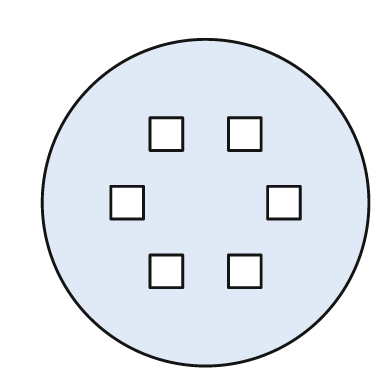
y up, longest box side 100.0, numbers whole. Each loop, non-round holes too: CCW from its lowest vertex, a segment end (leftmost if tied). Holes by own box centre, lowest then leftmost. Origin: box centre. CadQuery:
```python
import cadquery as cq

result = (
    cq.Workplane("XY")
    .moveTo(0.0, 0.0)
    .circle(50.0)
    .moveTo(-17.0, -26.0)
    .lineTo(-7.0, -26.0)
    .lineTo(-7.0, -16.0)
    .lineTo(-17.0, -16.0)
    .close()
    .moveTo(7.0, -26.0)
    .lineTo(17.0, -26.0)
    .lineTo(17.0, -16.0)
    .lineTo(7.0, -16.0)
    .close()
    .moveTo(-29.0, -5.0)
    .lineTo(-19.0, -5.0)
    .lineTo(-19.0, 5.0)
    .lineTo(-29.0, 5.0)
    .close()
    .moveTo(19.0, -5.0)
    .lineTo(29.0, -5.0)
    .lineTo(29.0, 5.0)
    .lineTo(19.0, 5.0)
    .close()
    .moveTo(-17.0, 16.0)
    .lineTo(-7.0, 16.0)
    .lineTo(-7.0, 26.0)
    .lineTo(-17.0, 26.0)
    .close()
    .moveTo(7.0, 16.0)
    .lineTo(17.0, 16.0)
    .lineTo(17.0, 26.0)
    .lineTo(7.0, 26.0)
    .close()
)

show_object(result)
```